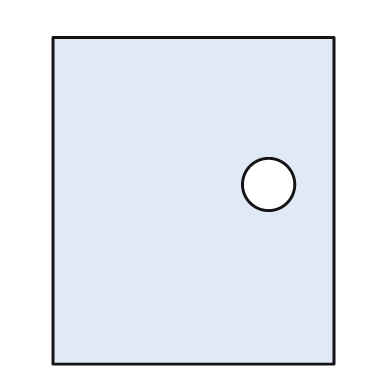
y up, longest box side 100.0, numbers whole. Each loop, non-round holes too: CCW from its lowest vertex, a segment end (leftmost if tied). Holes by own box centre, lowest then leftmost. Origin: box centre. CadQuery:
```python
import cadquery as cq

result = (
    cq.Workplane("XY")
    .moveTo(-43.0, -50.0)
    .lineTo(43.0, -50.0)
    .lineTo(43.0, 50.0)
    .lineTo(-43.0, 50.0)
    .close()
    .moveTo(23.0, 5.0)
    .circle(8.0)
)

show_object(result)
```